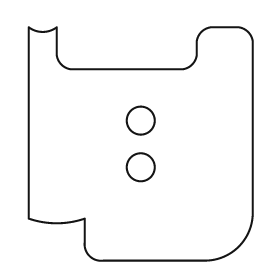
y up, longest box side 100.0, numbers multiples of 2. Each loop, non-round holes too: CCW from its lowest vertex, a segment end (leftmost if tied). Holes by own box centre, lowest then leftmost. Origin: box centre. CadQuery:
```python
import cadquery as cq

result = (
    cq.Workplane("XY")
    .moveTo(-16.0, -50.0)
    .lineTo(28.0, -50.0)
    .threePointArc((42.0, -44.0), (48.0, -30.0))
    .lineTo(48.0, 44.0)
    .threePointArc((46.0, 48.0), (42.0, 50.0))
    .lineTo(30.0, 50.0)
    .threePointArc((26.0, 48.0), (24.0, 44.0))
    .lineTo(24.0, 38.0)
    .threePointArc((22.0, 34.0), (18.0, 32.0))
    .lineTo(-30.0, 32.0)
    .threePointArc((-34.0, 34.0), (-36.0, 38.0))
    .lineTo(-36.0, 50.0)
    .threePointArc((-42.0, 48.0), (-48.0, 50.0))
    .lineTo(-48.0, -32.0)
    .threePointArc((-36.0, -34.0), (-24.0, -32.0))
    .lineTo(-24.0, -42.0)
    .threePointArc((-22.0, -48.0), (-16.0, -50.0))
    .close()
    .moveTo(0.0, -10.0)
    .circle(6.0)
    .moveTo(0.0, 10.0)
    .circle(6.0)
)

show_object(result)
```